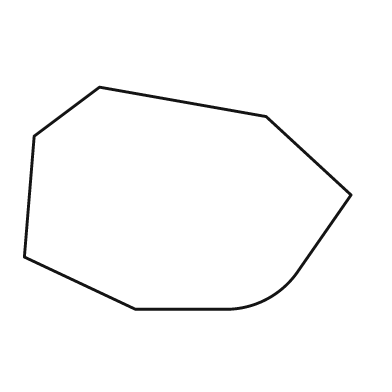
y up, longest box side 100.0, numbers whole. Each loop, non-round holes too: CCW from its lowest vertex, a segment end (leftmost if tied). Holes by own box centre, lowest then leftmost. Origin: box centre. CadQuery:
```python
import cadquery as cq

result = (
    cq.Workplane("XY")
    .moveTo(-16.0, -34.0)
    .lineTo(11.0, -34.0)
    .threePointArc((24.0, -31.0), (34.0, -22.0))
    .lineTo(50.0, 1.0)
    .lineTo(24.0, 25.0)
    .lineTo(-27.0, 34.0)
    .lineTo(-47.0, 19.0)
    .lineTo(-50.0, -18.0)
    .close()
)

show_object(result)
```